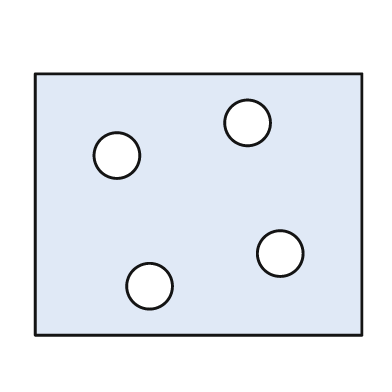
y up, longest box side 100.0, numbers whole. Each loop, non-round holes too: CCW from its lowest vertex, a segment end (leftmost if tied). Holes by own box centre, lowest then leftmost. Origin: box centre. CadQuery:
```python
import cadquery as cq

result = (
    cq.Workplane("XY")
    .moveTo(-50.0, -40.0)
    .lineTo(50.0, -40.0)
    .lineTo(50.0, 40.0)
    .lineTo(-50.0, 40.0)
    .close()
    .moveTo(-15.0, -25.0)
    .circle(7.0)
    .moveTo(25.0, -15.0)
    .circle(7.0)
    .moveTo(-25.0, 15.0)
    .circle(7.0)
    .moveTo(15.0, 25.0)
    .circle(7.0)
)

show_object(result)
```